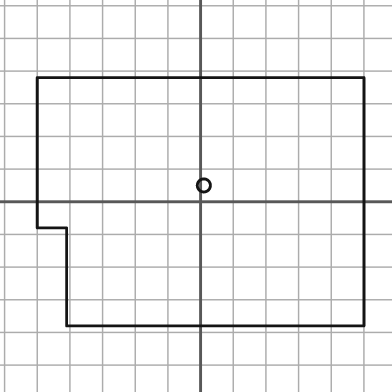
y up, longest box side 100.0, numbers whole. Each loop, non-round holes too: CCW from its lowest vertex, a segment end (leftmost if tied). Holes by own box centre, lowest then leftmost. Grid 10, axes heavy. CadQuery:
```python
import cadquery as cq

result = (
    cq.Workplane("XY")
    .moveTo(-41.0, -38.0)
    .lineTo(50.0, -38.0)
    .lineTo(50.0, 38.0)
    .lineTo(-50.0, 38.0)
    .lineTo(-50.0, -8.0)
    .lineTo(-41.0, -8.0)
    .close()
    .moveTo(1.0, 5.0)
    .circle(2.0)
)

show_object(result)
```